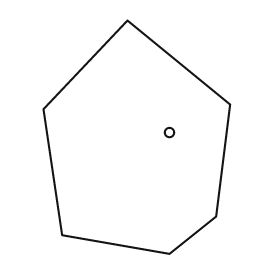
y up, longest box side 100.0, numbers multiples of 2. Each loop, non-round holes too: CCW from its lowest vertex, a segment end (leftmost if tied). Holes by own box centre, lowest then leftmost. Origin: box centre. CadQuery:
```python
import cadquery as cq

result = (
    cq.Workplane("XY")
    .moveTo(14.0, -50.0)
    .lineTo(34.0, -34.0)
    .lineTo(40.0, 14.0)
    .lineTo(-4.0, 50.0)
    .lineTo(-40.0, 12.0)
    .lineTo(-32.0, -42.0)
    .close()
    .moveTo(14.0, 2.0)
    .circle(2.0)
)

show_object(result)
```